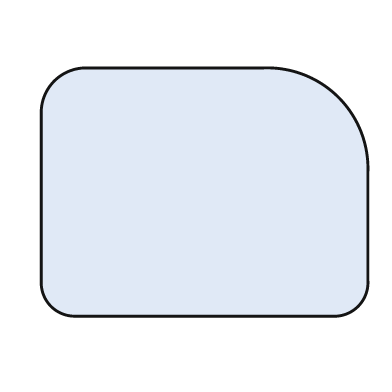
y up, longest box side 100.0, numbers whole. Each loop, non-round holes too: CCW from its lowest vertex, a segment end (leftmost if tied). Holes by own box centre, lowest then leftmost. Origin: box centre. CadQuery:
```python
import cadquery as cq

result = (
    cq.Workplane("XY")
    .moveTo(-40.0, -38.0)
    .lineTo(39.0, -38.0)
    .threePointArc((47.0, -35.0), (50.0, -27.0))
    .lineTo(50.0, 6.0)
    .threePointArc((41.0, 29.0), (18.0, 38.0))
    .lineTo(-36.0, 38.0)
    .threePointArc((-46.0, 34.0), (-50.0, 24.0))
    .lineTo(-50.0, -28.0)
    .threePointArc((-47.0, -35.0), (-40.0, -38.0))
    .close()
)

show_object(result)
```